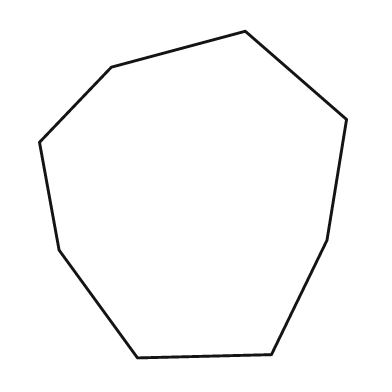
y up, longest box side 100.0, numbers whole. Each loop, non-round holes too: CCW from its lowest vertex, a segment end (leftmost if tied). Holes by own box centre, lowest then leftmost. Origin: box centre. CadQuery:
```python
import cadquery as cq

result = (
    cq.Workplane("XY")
    .moveTo(-17.0, -50.0)
    .lineTo(24.0, -49.0)
    .lineTo(41.0, -14.0)
    .lineTo(47.0, 23.0)
    .lineTo(16.0, 50.0)
    .lineTo(-25.0, 39.0)
    .lineTo(-47.0, 16.0)
    .lineTo(-41.0, -17.0)
    .close()
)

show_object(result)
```